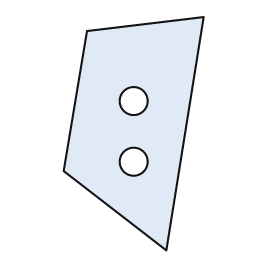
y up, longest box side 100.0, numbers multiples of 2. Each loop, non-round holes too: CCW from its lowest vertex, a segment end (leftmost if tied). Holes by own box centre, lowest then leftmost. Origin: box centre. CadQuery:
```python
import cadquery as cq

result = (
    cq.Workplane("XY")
    .moveTo(14.0, -50.0)
    .lineTo(30.0, 50.0)
    .lineTo(-20.0, 44.0)
    .lineTo(-30.0, -16.0)
    .close()
    .moveTo(0.0, -12.0)
    .circle(6.0)
    .moveTo(0.0, 14.0)
    .circle(6.0)
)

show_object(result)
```